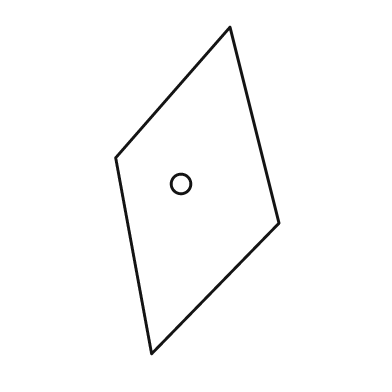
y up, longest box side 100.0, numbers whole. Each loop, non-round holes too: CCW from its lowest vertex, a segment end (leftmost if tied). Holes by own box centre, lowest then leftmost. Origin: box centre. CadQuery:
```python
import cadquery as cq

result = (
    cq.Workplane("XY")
    .moveTo(-14.0, -50.0)
    .lineTo(25.0, -10.0)
    .lineTo(10.0, 50.0)
    .lineTo(-25.0, 10.0)
    .close()
    .moveTo(-5.0, 2.0)
    .circle(3.0)
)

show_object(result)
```